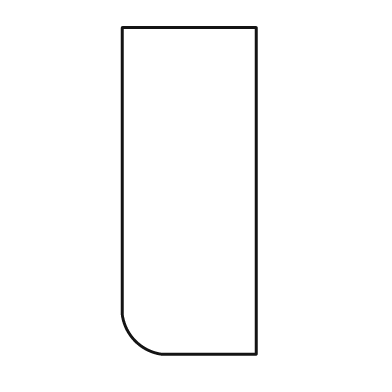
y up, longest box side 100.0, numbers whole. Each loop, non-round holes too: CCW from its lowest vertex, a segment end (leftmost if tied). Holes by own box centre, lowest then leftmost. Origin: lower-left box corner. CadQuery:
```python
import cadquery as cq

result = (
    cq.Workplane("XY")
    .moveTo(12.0, 0.0)
    .lineTo(41.0, 0.0)
    .lineTo(41.0, 100.0)
    .lineTo(0.0, 100.0)
    .lineTo(0.0, 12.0)
    .threePointArc((4.0, 4.0), (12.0, 0.0))
    .close()
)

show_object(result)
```